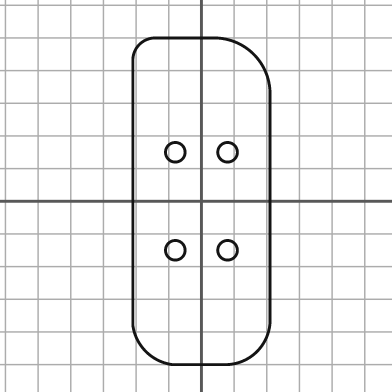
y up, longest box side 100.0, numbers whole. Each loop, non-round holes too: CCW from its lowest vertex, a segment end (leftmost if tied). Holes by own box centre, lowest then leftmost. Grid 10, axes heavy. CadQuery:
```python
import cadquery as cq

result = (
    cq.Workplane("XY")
    .moveTo(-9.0, -50.0)
    .lineTo(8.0, -50.0)
    .threePointArc((17.0, -46.0), (21.0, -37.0))
    .lineTo(21.0, 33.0)
    .threePointArc((16.0, 45.0), (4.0, 50.0))
    .lineTo(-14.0, 50.0)
    .threePointArc((-19.0, 48.0), (-21.0, 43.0))
    .lineTo(-21.0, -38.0)
    .threePointArc((-17.0, -46.0), (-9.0, -50.0))
    .close()
    .moveTo(-8.0, -15.0)
    .circle(3.0)
    .moveTo(8.0, -15.0)
    .circle(3.0)
    .moveTo(-8.0, 15.0)
    .circle(3.0)
    .moveTo(8.0, 15.0)
    .circle(3.0)
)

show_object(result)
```